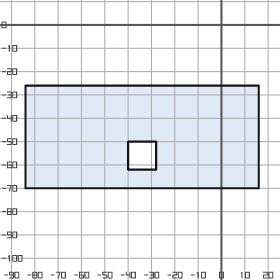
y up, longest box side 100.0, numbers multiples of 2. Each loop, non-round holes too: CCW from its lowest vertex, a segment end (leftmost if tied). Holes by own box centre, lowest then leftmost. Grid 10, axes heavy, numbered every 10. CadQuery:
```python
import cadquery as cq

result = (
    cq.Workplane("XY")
    .moveTo(-84.0, -70.0)
    .lineTo(16.0, -70.0)
    .lineTo(16.0, -26.0)
    .lineTo(-84.0, -26.0)
    .close()
    .moveTo(-40.0, -62.0)
    .lineTo(-28.0, -62.0)
    .lineTo(-28.0, -50.0)
    .lineTo(-40.0, -50.0)
    .close()
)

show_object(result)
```